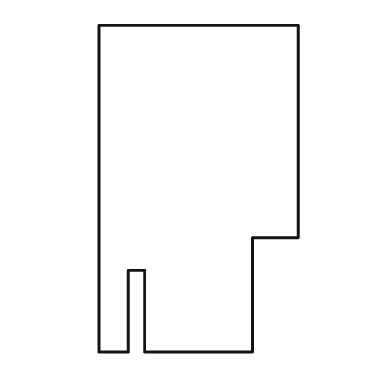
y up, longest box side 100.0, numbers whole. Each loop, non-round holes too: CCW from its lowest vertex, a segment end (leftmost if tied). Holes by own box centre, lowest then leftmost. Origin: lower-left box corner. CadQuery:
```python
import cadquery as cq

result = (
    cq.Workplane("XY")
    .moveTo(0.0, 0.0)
    .lineTo(9.0, 0.0)
    .lineTo(9.0, 25.0)
    .lineTo(14.0, 25.0)
    .lineTo(14.0, 0.0)
    .lineTo(47.0, 0.0)
    .lineTo(47.0, 35.0)
    .lineTo(61.0, 35.0)
    .lineTo(61.0, 100.0)
    .lineTo(0.0, 100.0)
    .close()
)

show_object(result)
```